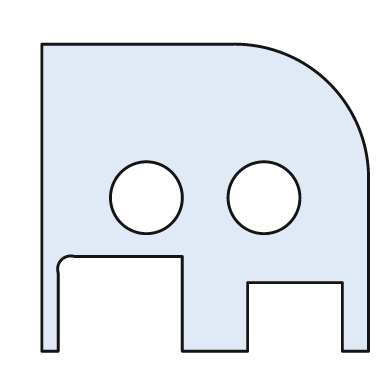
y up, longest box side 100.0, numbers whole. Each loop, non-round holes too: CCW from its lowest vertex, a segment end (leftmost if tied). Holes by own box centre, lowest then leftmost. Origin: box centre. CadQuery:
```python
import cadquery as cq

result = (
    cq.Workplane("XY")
    .moveTo(-50.0, -47.0)
    .lineTo(-45.0, -47.0)
    .lineTo(-45.0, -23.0)
    .threePointArc((-44.0, -19.0), (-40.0, -18.0))
    .lineTo(-7.0, -18.0)
    .lineTo(-7.0, -47.0)
    .lineTo(13.0, -47.0)
    .lineTo(13.0, -26.0)
    .lineTo(42.0, -26.0)
    .lineTo(42.0, -47.0)
    .lineTo(50.0, -47.0)
    .lineTo(50.0, 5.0)
    .threePointArc((38.0, 35.0), (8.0, 47.0))
    .lineTo(-50.0, 47.0)
    .close()
    .moveTo(-18.0, 0.0)
    .circle(11.0)
    .moveTo(18.0, 0.0)
    .circle(11.0)
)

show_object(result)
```